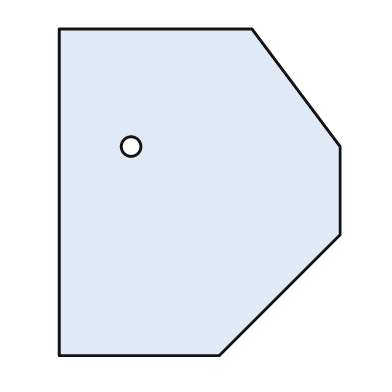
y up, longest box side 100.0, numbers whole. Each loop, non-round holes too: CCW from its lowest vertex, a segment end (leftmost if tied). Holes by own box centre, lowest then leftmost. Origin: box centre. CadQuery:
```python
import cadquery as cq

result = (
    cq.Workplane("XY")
    .moveTo(-43.0, -50.0)
    .lineTo(6.0, -50.0)
    .lineTo(43.0, -13.0)
    .lineTo(43.0, 14.0)
    .lineTo(16.0, 50.0)
    .lineTo(-43.0, 50.0)
    .close()
    .moveTo(-21.0, 14.0)
    .circle(3.0)
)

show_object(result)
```